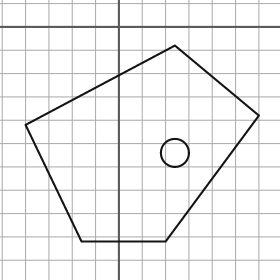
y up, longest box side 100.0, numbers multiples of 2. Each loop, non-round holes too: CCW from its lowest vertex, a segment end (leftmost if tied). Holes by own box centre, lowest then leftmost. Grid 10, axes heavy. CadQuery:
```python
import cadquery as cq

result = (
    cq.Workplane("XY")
    .moveTo(-16.0, -92.0)
    .lineTo(20.0, -92.0)
    .lineTo(60.0, -38.0)
    .lineTo(24.0, -8.0)
    .lineTo(-40.0, -42.0)
    .close()
    .moveTo(24.0, -54.0)
    .circle(6.0)
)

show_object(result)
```